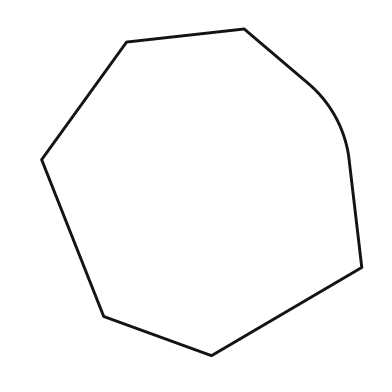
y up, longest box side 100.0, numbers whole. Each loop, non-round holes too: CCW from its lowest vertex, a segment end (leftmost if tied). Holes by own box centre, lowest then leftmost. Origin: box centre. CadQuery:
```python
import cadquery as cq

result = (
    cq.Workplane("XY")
    .moveTo(3.0, -50.0)
    .lineTo(49.0, -23.0)
    .lineTo(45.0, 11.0)
    .threePointArc((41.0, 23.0), (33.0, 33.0))
    .lineTo(13.0, 50.0)
    .lineTo(-23.0, 46.0)
    .lineTo(-49.0, 10.0)
    .lineTo(-30.0, -38.0)
    .close()
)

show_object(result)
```